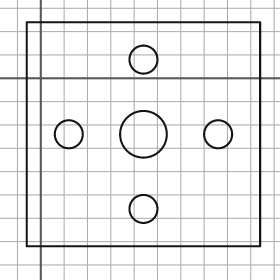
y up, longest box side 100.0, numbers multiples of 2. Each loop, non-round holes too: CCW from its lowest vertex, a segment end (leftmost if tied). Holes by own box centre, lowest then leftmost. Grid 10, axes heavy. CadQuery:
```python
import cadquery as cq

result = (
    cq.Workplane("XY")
    .moveTo(-6.0, -72.0)
    .lineTo(94.0, -72.0)
    .lineTo(94.0, 24.0)
    .lineTo(-6.0, 24.0)
    .close()
    .moveTo(44.0, -56.0)
    .circle(6.0)
    .moveTo(12.0, -24.0)
    .circle(6.0)
    .moveTo(44.0, -24.0)
    .circle(10.0)
    .moveTo(76.0, -24.0)
    .circle(6.0)
    .moveTo(44.0, 8.0)
    .circle(6.0)
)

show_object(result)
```